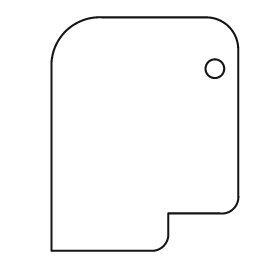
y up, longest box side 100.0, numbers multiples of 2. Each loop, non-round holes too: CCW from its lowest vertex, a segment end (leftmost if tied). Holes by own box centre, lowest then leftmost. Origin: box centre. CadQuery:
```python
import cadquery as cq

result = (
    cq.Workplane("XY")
    .moveTo(-40.0, -50.0)
    .lineTo(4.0, -50.0)
    .threePointArc((8.0, -48.0), (10.0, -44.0))
    .lineTo(10.0, -34.0)
    .lineTo(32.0, -34.0)
    .threePointArc((38.0, -32.0), (40.0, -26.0))
    .lineTo(40.0, 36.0)
    .threePointArc((36.0, 46.0), (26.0, 50.0))
    .lineTo(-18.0, 50.0)
    .threePointArc((-34.0, 44.0), (-40.0, 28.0))
    .close()
    .moveTo(30.0, 28.0)
    .circle(4.0)
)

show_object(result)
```